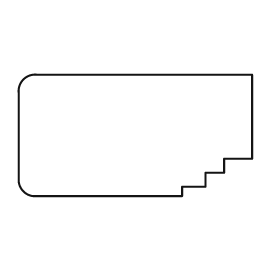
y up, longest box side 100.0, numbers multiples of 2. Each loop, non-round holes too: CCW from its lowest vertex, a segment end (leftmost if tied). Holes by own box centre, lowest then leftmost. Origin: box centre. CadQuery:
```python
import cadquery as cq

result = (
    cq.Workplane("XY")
    .moveTo(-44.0, -26.0)
    .lineTo(20.0, -26.0)
    .lineTo(20.0, -22.0)
    .lineTo(30.0, -22.0)
    .lineTo(30.0, -16.0)
    .lineTo(38.0, -16.0)
    .lineTo(38.0, -10.0)
    .lineTo(50.0, -10.0)
    .lineTo(50.0, 26.0)
    .lineTo(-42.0, 26.0)
    .threePointArc((-48.0, 24.0), (-50.0, 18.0))
    .lineTo(-50.0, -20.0)
    .threePointArc((-48.0, -24.0), (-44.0, -26.0))
    .close()
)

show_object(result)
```